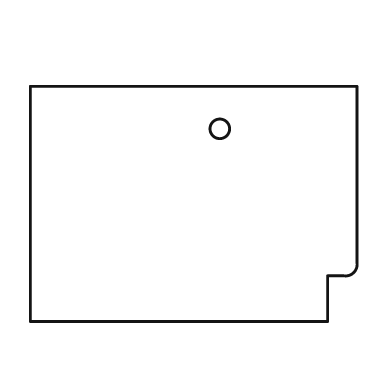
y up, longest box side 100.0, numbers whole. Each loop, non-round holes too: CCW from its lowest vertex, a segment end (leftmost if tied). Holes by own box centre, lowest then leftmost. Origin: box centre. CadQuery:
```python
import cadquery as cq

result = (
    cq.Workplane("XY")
    .moveTo(-50.0, -36.0)
    .lineTo(41.0, -36.0)
    .lineTo(41.0, -22.0)
    .lineTo(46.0, -22.0)
    .threePointArc((49.0, -21.0), (50.0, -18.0))
    .lineTo(50.0, 36.0)
    .lineTo(-50.0, 36.0)
    .close()
    .moveTo(8.0, 23.0)
    .circle(3.0)
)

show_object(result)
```